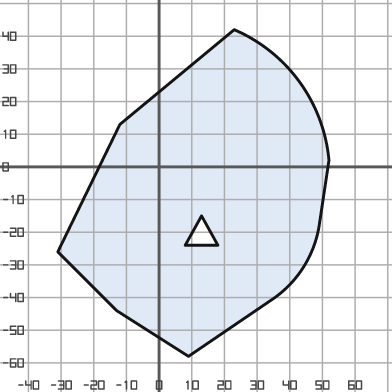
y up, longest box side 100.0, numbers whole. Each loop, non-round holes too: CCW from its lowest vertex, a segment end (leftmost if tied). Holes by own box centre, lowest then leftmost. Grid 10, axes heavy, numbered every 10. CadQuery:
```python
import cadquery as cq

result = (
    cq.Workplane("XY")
    .moveTo(9.0, -58.0)
    .lineTo(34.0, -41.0)
    .threePointArc((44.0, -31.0), (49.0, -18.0))
    .lineTo(52.0, 2.0)
    .threePointArc((43.0, 26.0), (23.0, 42.0))
    .lineTo(-12.0, 13.0)
    .lineTo(-31.0, -26.0)
    .lineTo(-13.0, -44.0)
    .close()
    .moveTo(8.0, -24.0)
    .lineTo(18.0, -24.0)
    .lineTo(13.0, -15.0)
    .close()
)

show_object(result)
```